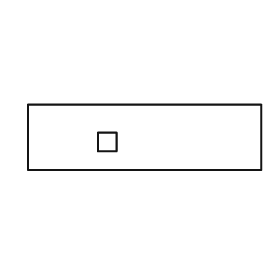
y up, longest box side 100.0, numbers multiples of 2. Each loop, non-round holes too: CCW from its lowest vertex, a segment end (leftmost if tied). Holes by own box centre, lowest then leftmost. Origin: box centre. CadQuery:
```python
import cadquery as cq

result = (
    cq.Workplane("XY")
    .moveTo(-50.0, -14.0)
    .lineTo(50.0, -14.0)
    .lineTo(50.0, 14.0)
    .lineTo(-50.0, 14.0)
    .close()
    .moveTo(-20.0, -6.0)
    .lineTo(-12.0, -6.0)
    .lineTo(-12.0, 2.0)
    .lineTo(-20.0, 2.0)
    .close()
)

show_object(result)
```